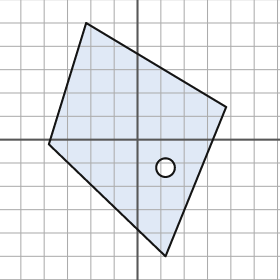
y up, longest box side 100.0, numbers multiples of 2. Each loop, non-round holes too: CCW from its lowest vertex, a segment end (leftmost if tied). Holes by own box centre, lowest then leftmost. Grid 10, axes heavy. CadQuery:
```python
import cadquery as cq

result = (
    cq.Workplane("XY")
    .moveTo(12.0, -50.0)
    .lineTo(38.0, 14.0)
    .lineTo(-22.0, 50.0)
    .lineTo(-38.0, -2.0)
    .close()
    .moveTo(12.0, -12.0)
    .circle(4.0)
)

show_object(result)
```